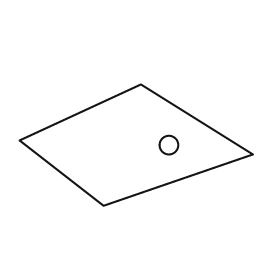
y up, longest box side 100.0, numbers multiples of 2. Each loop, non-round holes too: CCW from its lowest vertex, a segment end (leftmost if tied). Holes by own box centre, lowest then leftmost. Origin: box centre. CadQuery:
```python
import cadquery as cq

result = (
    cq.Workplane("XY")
    .moveTo(-14.0, -26.0)
    .lineTo(50.0, -4.0)
    .lineTo(2.0, 26.0)
    .lineTo(-50.0, 2.0)
    .close()
    .moveTo(14.0, 0.0)
    .circle(4.0)
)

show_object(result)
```